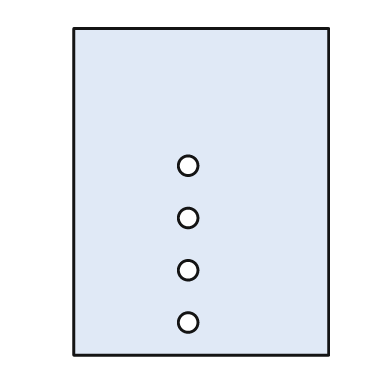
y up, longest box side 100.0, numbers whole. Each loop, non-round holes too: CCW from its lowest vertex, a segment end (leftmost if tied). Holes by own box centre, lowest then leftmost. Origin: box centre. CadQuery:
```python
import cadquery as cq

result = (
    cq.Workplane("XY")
    .moveTo(-39.0, -50.0)
    .lineTo(39.0, -50.0)
    .lineTo(39.0, 50.0)
    .lineTo(-39.0, 50.0)
    .close()
    .moveTo(-4.0, -40.0)
    .circle(3.0)
    .moveTo(-4.0, -24.0)
    .circle(3.0)
    .moveTo(-4.0, -8.0)
    .circle(3.0)
    .moveTo(-4.0, 8.0)
    .circle(3.0)
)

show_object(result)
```